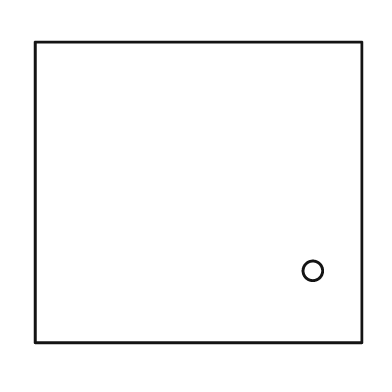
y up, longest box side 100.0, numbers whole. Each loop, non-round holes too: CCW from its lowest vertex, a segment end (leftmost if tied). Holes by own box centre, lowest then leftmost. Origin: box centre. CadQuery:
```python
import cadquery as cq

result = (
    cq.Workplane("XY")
    .moveTo(-50.0, -46.0)
    .lineTo(50.0, -46.0)
    .lineTo(50.0, 46.0)
    .lineTo(-50.0, 46.0)
    .close()
    .moveTo(35.0, -24.0)
    .circle(3.0)
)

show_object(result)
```